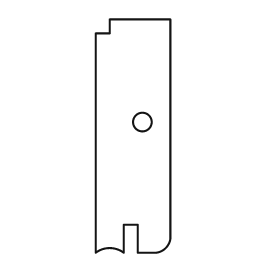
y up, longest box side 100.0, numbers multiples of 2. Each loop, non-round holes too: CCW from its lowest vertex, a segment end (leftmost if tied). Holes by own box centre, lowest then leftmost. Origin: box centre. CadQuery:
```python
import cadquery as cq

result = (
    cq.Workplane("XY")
    .moveTo(-16.0, -50.0)
    .threePointArc((-10.0, -48.0), (-4.0, -50.0))
    .lineTo(-4.0, -38.0)
    .lineTo(2.0, -38.0)
    .lineTo(2.0, -50.0)
    .lineTo(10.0, -50.0)
    .threePointArc((14.0, -48.0), (16.0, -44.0))
    .lineTo(16.0, 50.0)
    .lineTo(-10.0, 50.0)
    .lineTo(-10.0, 44.0)
    .lineTo(-16.0, 44.0)
    .close()
    .moveTo(4.0, 6.0)
    .circle(4.0)
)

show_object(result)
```